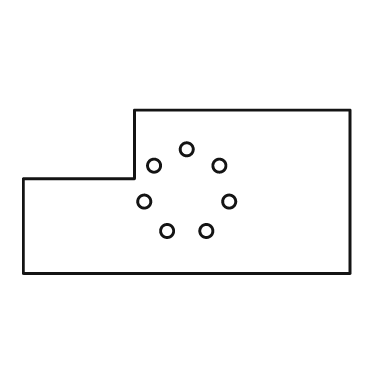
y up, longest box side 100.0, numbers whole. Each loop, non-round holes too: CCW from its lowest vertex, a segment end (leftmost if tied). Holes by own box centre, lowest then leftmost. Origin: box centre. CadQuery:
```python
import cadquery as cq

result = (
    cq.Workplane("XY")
    .moveTo(-50.0, -25.0)
    .lineTo(50.0, -25.0)
    .lineTo(50.0, 25.0)
    .lineTo(-16.0, 25.0)
    .lineTo(-16.0, 4.0)
    .lineTo(-50.0, 4.0)
    .close()
    .moveTo(-6.0, -12.0)
    .circle(2.0)
    .moveTo(6.0, -12.0)
    .circle(2.0)
    .moveTo(-13.0, -3.0)
    .circle(2.0)
    .moveTo(13.0, -3.0)
    .circle(2.0)
    .moveTo(-10.0, 8.0)
    .circle(2.0)
    .moveTo(10.0, 8.0)
    .circle(2.0)
    .moveTo(0.0, 13.0)
    .circle(2.0)
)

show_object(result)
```